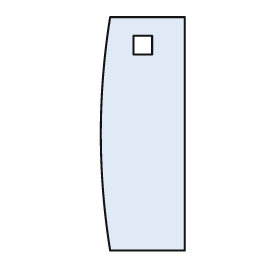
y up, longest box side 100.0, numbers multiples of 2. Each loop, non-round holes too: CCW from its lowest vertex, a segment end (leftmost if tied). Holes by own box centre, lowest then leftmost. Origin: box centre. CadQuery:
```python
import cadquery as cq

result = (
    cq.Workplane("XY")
    .moveTo(-14.0, -50.0)
    .lineTo(18.0, -50.0)
    .lineTo(18.0, 50.0)
    .lineTo(-14.0, 50.0)
    .threePointArc((-18.0, 0.0), (-14.0, -50.0))
    .close()
    .moveTo(-4.0, 34.0)
    .lineTo(4.0, 34.0)
    .lineTo(4.0, 42.0)
    .lineTo(-4.0, 42.0)
    .close()
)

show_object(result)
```